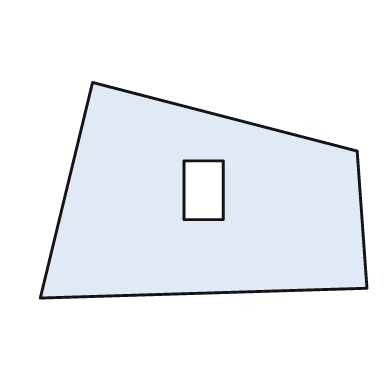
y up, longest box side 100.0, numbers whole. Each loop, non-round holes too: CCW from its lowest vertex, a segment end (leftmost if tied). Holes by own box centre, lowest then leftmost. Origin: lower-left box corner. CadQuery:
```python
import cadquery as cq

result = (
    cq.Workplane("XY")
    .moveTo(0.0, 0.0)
    .lineTo(100.0, 3.0)
    .lineTo(97.0, 45.0)
    .lineTo(16.0, 66.0)
    .close()
    .moveTo(44.0, 24.0)
    .lineTo(56.0, 24.0)
    .lineTo(56.0, 42.0)
    .lineTo(44.0, 42.0)
    .close()
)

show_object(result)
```